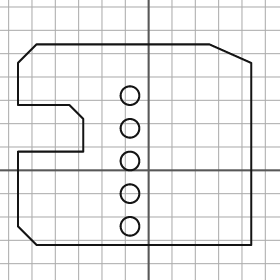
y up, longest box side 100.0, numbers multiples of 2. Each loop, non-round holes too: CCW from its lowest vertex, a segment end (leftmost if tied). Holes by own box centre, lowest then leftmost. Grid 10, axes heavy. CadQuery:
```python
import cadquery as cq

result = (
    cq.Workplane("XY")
    .moveTo(-48.0, -32.0)
    .lineTo(44.0, -32.0)
    .lineTo(44.0, 46.0)
    .lineTo(26.0, 54.0)
    .lineTo(-48.0, 54.0)
    .lineTo(-56.0, 46.0)
    .lineTo(-56.0, 28.0)
    .lineTo(-34.0, 28.0)
    .lineTo(-28.0, 22.0)
    .lineTo(-28.0, 8.0)
    .lineTo(-56.0, 8.0)
    .lineTo(-56.0, -24.0)
    .close()
    .moveTo(-8.0, -24.0)
    .circle(4.0)
    .moveTo(-8.0, -10.0)
    .circle(4.0)
    .moveTo(-8.0, 4.0)
    .circle(4.0)
    .moveTo(-8.0, 18.0)
    .circle(4.0)
    .moveTo(-8.0, 32.0)
    .circle(4.0)
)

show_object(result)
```